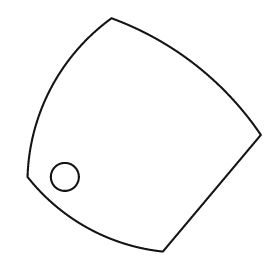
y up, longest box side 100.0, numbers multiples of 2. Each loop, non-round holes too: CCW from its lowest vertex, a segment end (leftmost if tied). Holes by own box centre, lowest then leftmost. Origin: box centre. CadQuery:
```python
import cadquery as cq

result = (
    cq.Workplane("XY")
    .moveTo(8.0, -50.0)
    .lineTo(50.0, 0.0)
    .threePointArc((22.0, 30.0), (-14.0, 50.0))
    .threePointArc((-40.0, 20.0), (-50.0, -18.0))
    .threePointArc((-24.0, -40.0), (8.0, -50.0))
    .close()
    .moveTo(-34.0, -18.0)
    .circle(6.0)
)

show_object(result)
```